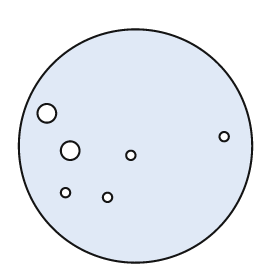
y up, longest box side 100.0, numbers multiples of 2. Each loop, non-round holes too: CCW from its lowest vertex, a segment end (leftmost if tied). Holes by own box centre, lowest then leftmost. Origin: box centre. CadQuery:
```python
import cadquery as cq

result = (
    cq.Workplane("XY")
    .moveTo(0.0, 0.0)
    .circle(50.0)
    .moveTo(-12.0, -22.0)
    .circle(2.0)
    .moveTo(-30.0, -20.0)
    .circle(2.0)
    .moveTo(-2.0, -4.0)
    .circle(2.0)
    .moveTo(-28.0, -2.0)
    .circle(4.0)
    .moveTo(38.0, 4.0)
    .circle(2.0)
    .moveTo(-38.0, 14.0)
    .circle(4.0)
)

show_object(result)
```